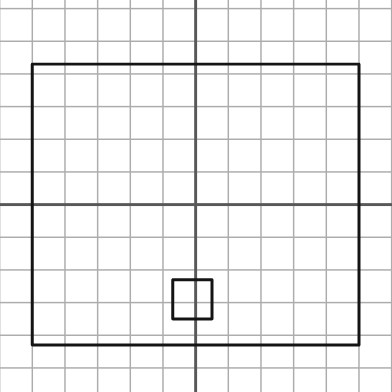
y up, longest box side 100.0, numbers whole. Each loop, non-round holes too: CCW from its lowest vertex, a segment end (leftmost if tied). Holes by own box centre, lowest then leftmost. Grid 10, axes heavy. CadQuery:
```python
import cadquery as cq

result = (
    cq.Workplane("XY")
    .moveTo(-50.0, -43.0)
    .lineTo(50.0, -43.0)
    .lineTo(50.0, 43.0)
    .lineTo(-50.0, 43.0)
    .close()
    .moveTo(-7.0, -35.0)
    .lineTo(5.0, -35.0)
    .lineTo(5.0, -23.0)
    .lineTo(-7.0, -23.0)
    .close()
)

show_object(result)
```